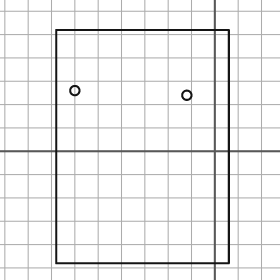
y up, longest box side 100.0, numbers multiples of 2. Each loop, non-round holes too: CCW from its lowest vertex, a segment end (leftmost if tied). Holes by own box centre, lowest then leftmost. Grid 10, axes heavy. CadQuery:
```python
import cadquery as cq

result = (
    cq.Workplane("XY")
    .moveTo(-68.0, -48.0)
    .lineTo(6.0, -48.0)
    .lineTo(6.0, 52.0)
    .lineTo(-68.0, 52.0)
    .close()
    .moveTo(-12.0, 24.0)
    .circle(2.0)
    .moveTo(-60.0, 26.0)
    .circle(2.0)
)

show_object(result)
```